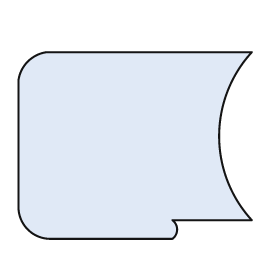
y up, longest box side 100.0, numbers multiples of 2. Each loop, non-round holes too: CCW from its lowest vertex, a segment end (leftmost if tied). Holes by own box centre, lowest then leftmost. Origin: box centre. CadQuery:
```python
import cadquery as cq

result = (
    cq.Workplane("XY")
    .moveTo(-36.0, -40.0)
    .lineTo(16.0, -40.0)
    .threePointArc((18.0, -36.0), (16.0, -32.0))
    .lineTo(50.0, -32.0)
    .threePointArc((36.0, 4.0), (50.0, 40.0))
    .lineTo(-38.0, 40.0)
    .threePointArc((-46.0, 36.0), (-50.0, 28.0))
    .lineTo(-50.0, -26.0)
    .threePointArc((-46.0, -36.0), (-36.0, -40.0))
    .close()
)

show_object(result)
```